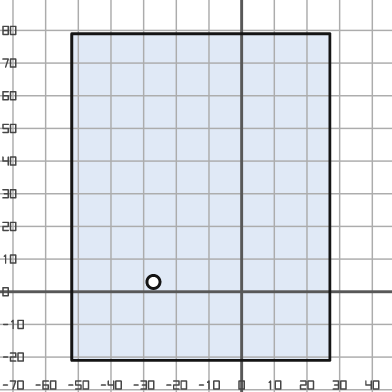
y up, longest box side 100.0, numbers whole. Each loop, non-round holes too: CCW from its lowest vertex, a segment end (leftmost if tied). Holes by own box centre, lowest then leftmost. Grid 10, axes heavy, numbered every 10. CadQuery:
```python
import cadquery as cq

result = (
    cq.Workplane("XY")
    .moveTo(-52.0, -21.0)
    .lineTo(27.0, -21.0)
    .lineTo(27.0, 79.0)
    .lineTo(-52.0, 79.0)
    .close()
    .moveTo(-27.0, 3.0)
    .circle(2.0)
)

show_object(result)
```